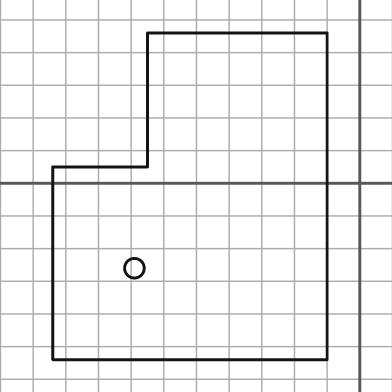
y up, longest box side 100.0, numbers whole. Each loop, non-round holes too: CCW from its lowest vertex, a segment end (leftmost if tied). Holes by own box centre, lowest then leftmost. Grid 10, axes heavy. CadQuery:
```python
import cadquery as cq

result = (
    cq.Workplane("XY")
    .moveTo(-94.0, -54.0)
    .lineTo(-10.0, -54.0)
    .lineTo(-10.0, 46.0)
    .lineTo(-65.0, 46.0)
    .lineTo(-65.0, 5.0)
    .lineTo(-94.0, 5.0)
    .close()
    .moveTo(-69.0, -26.0)
    .circle(3.0)
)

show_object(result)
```